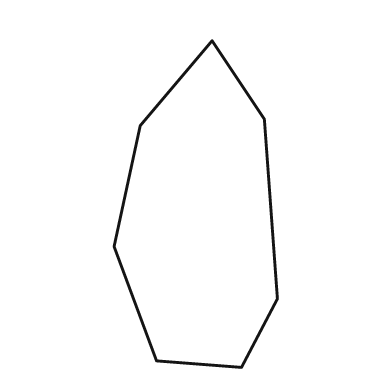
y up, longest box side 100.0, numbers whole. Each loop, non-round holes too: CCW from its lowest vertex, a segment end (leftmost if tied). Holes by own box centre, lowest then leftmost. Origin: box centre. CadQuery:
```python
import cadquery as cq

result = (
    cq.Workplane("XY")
    .moveTo(14.0, -50.0)
    .lineTo(25.0, -29.0)
    .lineTo(21.0, 26.0)
    .lineTo(5.0, 50.0)
    .lineTo(-17.0, 24.0)
    .lineTo(-25.0, -13.0)
    .lineTo(-12.0, -48.0)
    .close()
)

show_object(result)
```